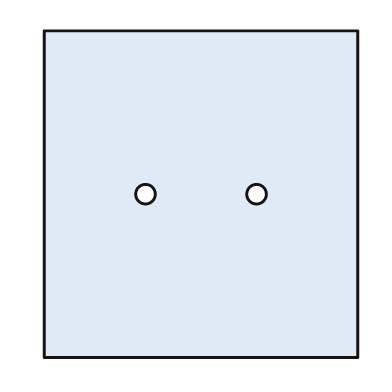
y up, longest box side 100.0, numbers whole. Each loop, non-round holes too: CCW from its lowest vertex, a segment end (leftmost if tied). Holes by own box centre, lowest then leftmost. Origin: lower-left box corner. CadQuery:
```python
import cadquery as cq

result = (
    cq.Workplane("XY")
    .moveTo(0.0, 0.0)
    .lineTo(96.0, 0.0)
    .lineTo(96.0, 100.0)
    .lineTo(0.0, 100.0)
    .close()
    .moveTo(31.0, 50.0)
    .circle(3.0)
    .moveTo(65.0, 50.0)
    .circle(3.0)
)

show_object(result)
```